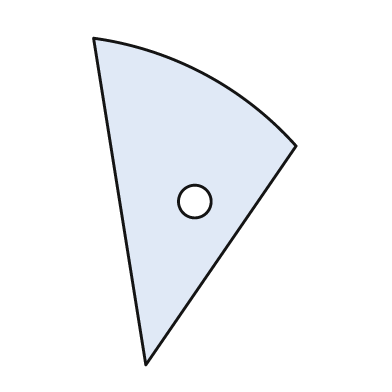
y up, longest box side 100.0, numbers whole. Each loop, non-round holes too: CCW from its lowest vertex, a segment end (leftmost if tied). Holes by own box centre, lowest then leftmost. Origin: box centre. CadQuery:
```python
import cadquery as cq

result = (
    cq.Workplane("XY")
    .moveTo(-15.0, -50.0)
    .lineTo(31.0, 17.0)
    .threePointArc((3.0, 39.0), (-31.0, 50.0))
    .close()
    .moveTo(0.0, 0.0)
    .circle(5.0)
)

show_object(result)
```